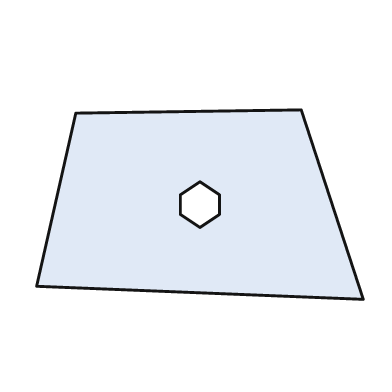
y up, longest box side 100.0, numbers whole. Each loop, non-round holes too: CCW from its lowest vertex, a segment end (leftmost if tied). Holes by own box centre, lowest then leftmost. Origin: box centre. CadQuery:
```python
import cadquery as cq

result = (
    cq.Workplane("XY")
    .moveTo(50.0, -29.0)
    .lineTo(31.0, 29.0)
    .lineTo(-38.0, 28.0)
    .lineTo(-50.0, -25.0)
    .close()
    .moveTo(0.0, -7.0)
    .lineTo(6.0, -3.0)
    .lineTo(6.0, 3.0)
    .lineTo(0.0, 7.0)
    .lineTo(-6.0, 3.0)
    .lineTo(-6.0, -3.0)
    .close()
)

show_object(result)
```